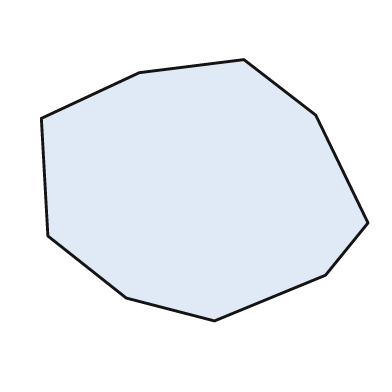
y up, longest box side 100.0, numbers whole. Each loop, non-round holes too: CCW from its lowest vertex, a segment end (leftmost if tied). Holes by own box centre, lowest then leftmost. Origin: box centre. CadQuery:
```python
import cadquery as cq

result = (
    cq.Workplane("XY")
    .moveTo(3.0, -40.0)
    .lineTo(37.0, -26.0)
    .lineTo(50.0, -10.0)
    .lineTo(34.0, 23.0)
    .lineTo(12.0, 40.0)
    .lineTo(-20.0, 36.0)
    .lineTo(-50.0, 22.0)
    .lineTo(-48.0, -14.0)
    .lineTo(-24.0, -33.0)
    .close()
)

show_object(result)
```